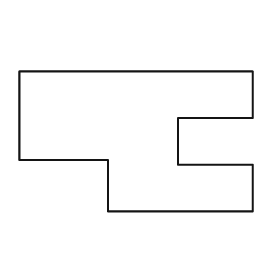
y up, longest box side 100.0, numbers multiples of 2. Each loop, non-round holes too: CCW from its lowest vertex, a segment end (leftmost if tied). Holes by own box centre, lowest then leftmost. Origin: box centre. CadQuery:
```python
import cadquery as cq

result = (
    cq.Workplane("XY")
    .moveTo(-12.0, -30.0)
    .lineTo(50.0, -30.0)
    .lineTo(50.0, -10.0)
    .lineTo(18.0, -10.0)
    .lineTo(18.0, 10.0)
    .lineTo(50.0, 10.0)
    .lineTo(50.0, 30.0)
    .lineTo(-50.0, 30.0)
    .lineTo(-50.0, -8.0)
    .lineTo(-12.0, -8.0)
    .close()
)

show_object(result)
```